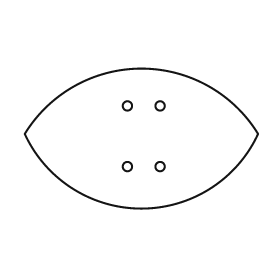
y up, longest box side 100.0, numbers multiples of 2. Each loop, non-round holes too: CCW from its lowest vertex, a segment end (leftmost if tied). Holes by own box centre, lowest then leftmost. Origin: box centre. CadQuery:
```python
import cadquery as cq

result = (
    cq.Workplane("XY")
    .moveTo(-50.0, 2.0)
    .threePointArc((0.0, -30.0), (50.0, 2.0))
    .threePointArc((0.0, 30.0), (-50.0, 2.0))
    .close()
    .moveTo(-6.0, -12.0)
    .circle(2.0)
    .moveTo(8.0, -12.0)
    .circle(2.0)
    .moveTo(-6.0, 14.0)
    .circle(2.0)
    .moveTo(8.0, 14.0)
    .circle(2.0)
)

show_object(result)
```